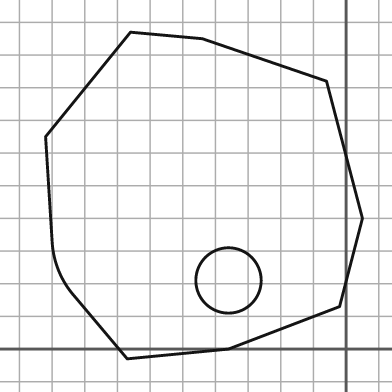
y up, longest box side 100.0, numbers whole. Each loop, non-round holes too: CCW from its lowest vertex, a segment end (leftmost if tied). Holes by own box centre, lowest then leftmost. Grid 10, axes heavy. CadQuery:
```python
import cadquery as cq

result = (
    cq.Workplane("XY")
    .moveTo(-67.0, -3.0)
    .lineTo(-36.0, 0.0)
    .lineTo(-2.0, 13.0)
    .lineTo(5.0, 40.0)
    .lineTo(-6.0, 82.0)
    .lineTo(-44.0, 95.0)
    .lineTo(-66.0, 97.0)
    .lineTo(-92.0, 65.0)
    .lineTo(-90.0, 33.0)
    .threePointArc((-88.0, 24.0), (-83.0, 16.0))
    .close()
    .moveTo(-36.0, 21.0)
    .circle(10.0)
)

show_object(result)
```